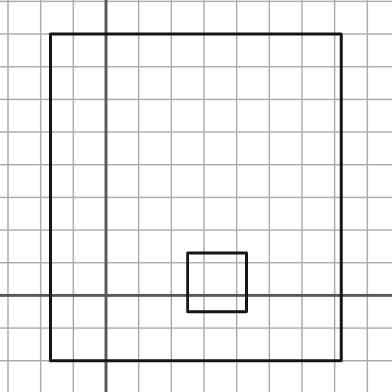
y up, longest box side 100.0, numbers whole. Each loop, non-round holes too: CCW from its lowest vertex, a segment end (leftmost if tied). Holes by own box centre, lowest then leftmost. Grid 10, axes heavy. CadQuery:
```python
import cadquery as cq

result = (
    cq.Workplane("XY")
    .moveTo(-17.0, -20.0)
    .lineTo(72.0, -20.0)
    .lineTo(72.0, 80.0)
    .lineTo(-17.0, 80.0)
    .close()
    .moveTo(25.0, -5.0)
    .lineTo(43.0, -5.0)
    .lineTo(43.0, 13.0)
    .lineTo(25.0, 13.0)
    .close()
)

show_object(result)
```